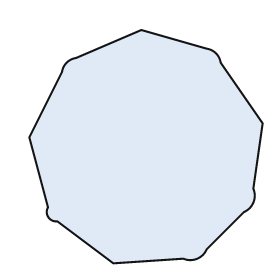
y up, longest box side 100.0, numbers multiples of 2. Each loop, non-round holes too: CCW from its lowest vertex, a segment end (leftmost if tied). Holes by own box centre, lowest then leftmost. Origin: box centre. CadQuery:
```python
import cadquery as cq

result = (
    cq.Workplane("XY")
    .moveTo(-14.0, -50.0)
    .lineTo(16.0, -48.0)
    .threePointArc((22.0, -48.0), (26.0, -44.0))
    .lineTo(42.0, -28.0)
    .threePointArc((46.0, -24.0), (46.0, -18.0))
    .lineTo(50.0, 10.0)
    .lineTo(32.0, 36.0)
    .threePointArc((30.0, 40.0), (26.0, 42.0))
    .lineTo(-2.0, 50.0)
    .lineTo(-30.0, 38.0)
    .threePointArc((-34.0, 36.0), (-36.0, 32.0))
    .lineTo(-50.0, 4.0)
    .lineTo(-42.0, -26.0)
    .threePointArc((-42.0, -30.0), (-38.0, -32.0))
    .close()
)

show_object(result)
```